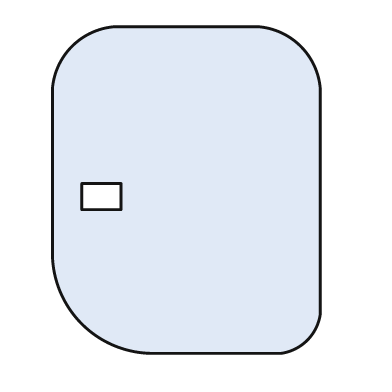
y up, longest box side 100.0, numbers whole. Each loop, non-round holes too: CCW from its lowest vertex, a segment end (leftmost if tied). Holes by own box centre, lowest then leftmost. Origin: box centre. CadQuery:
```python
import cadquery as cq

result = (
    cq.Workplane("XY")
    .moveTo(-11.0, -50.0)
    .lineTo(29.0, -50.0)
    .threePointArc((37.0, -46.0), (41.0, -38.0))
    .lineTo(41.0, 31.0)
    .threePointArc((35.0, 44.0), (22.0, 50.0))
    .lineTo(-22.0, 50.0)
    .threePointArc((-35.0, 44.0), (-41.0, 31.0))
    .lineTo(-41.0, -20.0)
    .threePointArc((-32.0, -41.0), (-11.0, -50.0))
    .close()
    .moveTo(-32.0, -6.0)
    .lineTo(-20.0, -6.0)
    .lineTo(-20.0, 2.0)
    .lineTo(-32.0, 2.0)
    .close()
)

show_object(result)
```